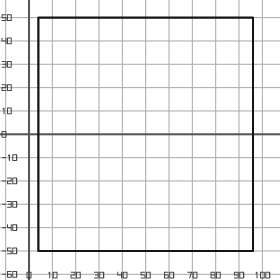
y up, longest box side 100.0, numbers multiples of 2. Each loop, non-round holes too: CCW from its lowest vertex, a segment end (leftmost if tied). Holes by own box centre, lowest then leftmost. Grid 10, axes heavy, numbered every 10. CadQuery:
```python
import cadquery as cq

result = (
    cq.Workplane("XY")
    .moveTo(4.0, -50.0)
    .lineTo(96.0, -50.0)
    .lineTo(96.0, 50.0)
    .lineTo(4.0, 50.0)
    .close()
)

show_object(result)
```